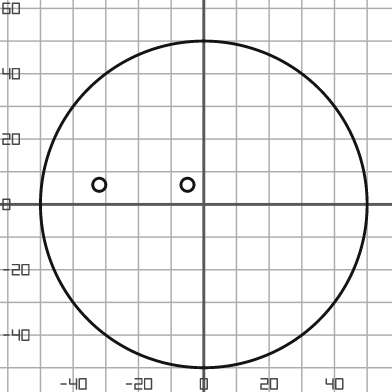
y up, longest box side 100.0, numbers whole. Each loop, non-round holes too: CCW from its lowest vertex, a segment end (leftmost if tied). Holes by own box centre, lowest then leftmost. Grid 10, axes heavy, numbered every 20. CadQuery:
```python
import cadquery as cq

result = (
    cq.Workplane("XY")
    .moveTo(0.0, 0.0)
    .circle(50.0)
    .moveTo(-32.0, 6.0)
    .circle(2.0)
    .moveTo(-5.0, 6.0)
    .circle(2.0)
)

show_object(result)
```